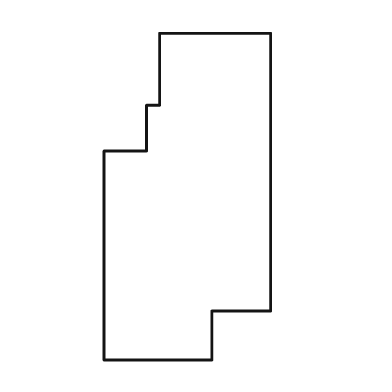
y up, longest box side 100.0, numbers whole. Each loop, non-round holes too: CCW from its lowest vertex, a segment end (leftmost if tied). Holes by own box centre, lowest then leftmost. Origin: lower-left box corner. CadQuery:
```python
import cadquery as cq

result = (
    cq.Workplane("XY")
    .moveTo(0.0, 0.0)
    .lineTo(33.0, 0.0)
    .lineTo(33.0, 15.0)
    .lineTo(51.0, 15.0)
    .lineTo(51.0, 100.0)
    .lineTo(17.0, 100.0)
    .lineTo(17.0, 78.0)
    .lineTo(13.0, 78.0)
    .lineTo(13.0, 64.0)
    .lineTo(0.0, 64.0)
    .close()
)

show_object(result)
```